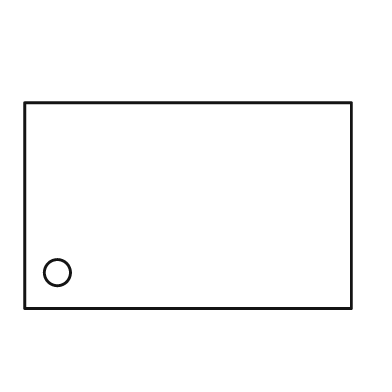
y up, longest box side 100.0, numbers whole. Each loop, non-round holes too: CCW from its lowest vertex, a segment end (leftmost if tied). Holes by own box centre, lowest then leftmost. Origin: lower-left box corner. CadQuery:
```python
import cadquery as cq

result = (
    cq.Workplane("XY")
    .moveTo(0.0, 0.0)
    .lineTo(100.0, 0.0)
    .lineTo(100.0, 63.0)
    .lineTo(0.0, 63.0)
    .close()
    .moveTo(10.0, 11.0)
    .circle(4.0)
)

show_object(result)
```